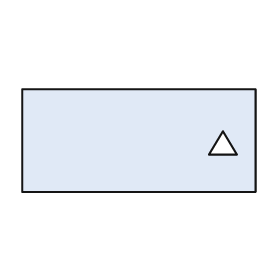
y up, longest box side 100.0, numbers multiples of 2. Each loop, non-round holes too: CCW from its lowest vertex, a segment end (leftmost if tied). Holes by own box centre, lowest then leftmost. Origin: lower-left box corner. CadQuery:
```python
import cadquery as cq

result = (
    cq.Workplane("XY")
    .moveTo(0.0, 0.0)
    .lineTo(100.0, 0.0)
    .lineTo(100.0, 44.0)
    .lineTo(0.0, 44.0)
    .close()
    .moveTo(80.0, 16.0)
    .lineTo(92.0, 16.0)
    .lineTo(86.0, 26.0)
    .close()
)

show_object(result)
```